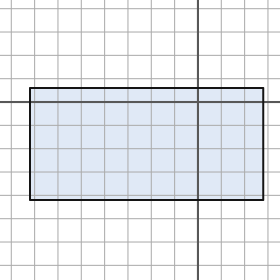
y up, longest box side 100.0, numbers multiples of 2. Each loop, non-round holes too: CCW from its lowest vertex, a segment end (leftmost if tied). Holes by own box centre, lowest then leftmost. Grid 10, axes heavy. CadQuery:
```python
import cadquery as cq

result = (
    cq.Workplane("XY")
    .moveTo(-72.0, -42.0)
    .lineTo(28.0, -42.0)
    .lineTo(28.0, 6.0)
    .lineTo(-72.0, 6.0)
    .close()
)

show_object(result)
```